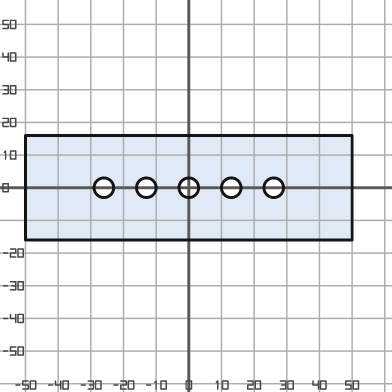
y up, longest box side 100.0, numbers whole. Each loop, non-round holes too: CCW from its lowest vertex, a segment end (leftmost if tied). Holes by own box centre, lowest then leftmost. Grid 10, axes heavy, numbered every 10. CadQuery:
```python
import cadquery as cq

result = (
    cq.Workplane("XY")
    .moveTo(-50.0, -16.0)
    .lineTo(50.0, -16.0)
    .lineTo(50.0, 16.0)
    .lineTo(-50.0, 16.0)
    .close()
    .moveTo(-26.0, 0.0)
    .circle(3.0)
    .moveTo(-13.0, 0.0)
    .circle(3.0)
    .moveTo(0.0, 0.0)
    .circle(3.0)
    .moveTo(13.0, 0.0)
    .circle(3.0)
    .moveTo(26.0, 0.0)
    .circle(3.0)
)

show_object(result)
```